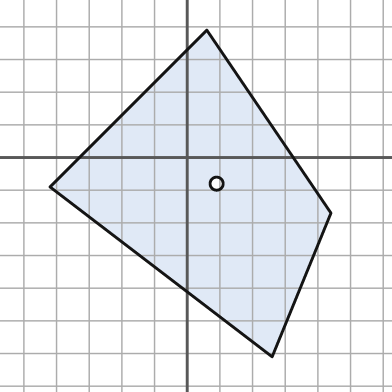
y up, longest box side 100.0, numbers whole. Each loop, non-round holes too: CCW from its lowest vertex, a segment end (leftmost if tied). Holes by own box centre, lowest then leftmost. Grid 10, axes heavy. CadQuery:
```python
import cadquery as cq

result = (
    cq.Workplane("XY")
    .moveTo(26.0, -61.0)
    .lineTo(44.0, -17.0)
    .lineTo(6.0, 39.0)
    .lineTo(-42.0, -9.0)
    .close()
    .moveTo(9.0, -8.0)
    .circle(2.0)
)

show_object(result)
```